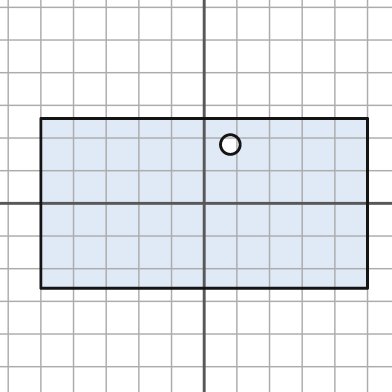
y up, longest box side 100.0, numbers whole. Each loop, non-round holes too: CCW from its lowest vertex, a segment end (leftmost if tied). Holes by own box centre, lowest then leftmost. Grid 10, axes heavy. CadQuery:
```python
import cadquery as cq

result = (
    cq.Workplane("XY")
    .moveTo(-50.0, -26.0)
    .lineTo(50.0, -26.0)
    .lineTo(50.0, 26.0)
    .lineTo(-50.0, 26.0)
    .close()
    .moveTo(8.0, 18.0)
    .circle(3.0)
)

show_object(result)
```